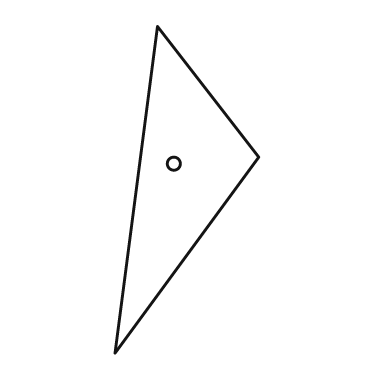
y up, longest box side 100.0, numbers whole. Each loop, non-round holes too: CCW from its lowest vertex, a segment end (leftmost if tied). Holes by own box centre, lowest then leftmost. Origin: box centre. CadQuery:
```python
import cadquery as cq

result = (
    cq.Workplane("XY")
    .moveTo(-22.0, -50.0)
    .lineTo(22.0, 10.0)
    .lineTo(-9.0, 50.0)
    .close()
    .moveTo(-4.0, 8.0)
    .circle(2.0)
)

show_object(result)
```